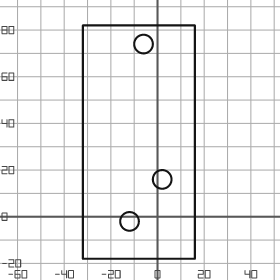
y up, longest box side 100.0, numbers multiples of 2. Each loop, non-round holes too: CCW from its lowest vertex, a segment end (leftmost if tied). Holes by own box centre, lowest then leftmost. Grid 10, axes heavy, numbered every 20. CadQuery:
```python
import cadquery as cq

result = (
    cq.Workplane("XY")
    .moveTo(-32.0, -18.0)
    .lineTo(16.0, -18.0)
    .lineTo(16.0, 82.0)
    .lineTo(-32.0, 82.0)
    .close()
    .moveTo(-12.0, -2.0)
    .circle(4.0)
    .moveTo(2.0, 16.0)
    .circle(4.0)
    .moveTo(-6.0, 74.0)
    .circle(4.0)
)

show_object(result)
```